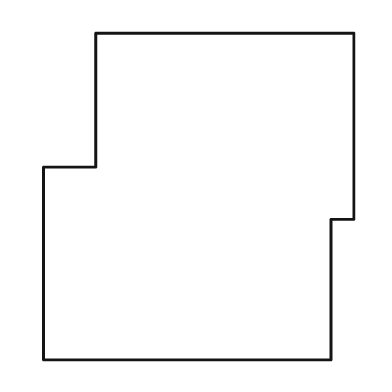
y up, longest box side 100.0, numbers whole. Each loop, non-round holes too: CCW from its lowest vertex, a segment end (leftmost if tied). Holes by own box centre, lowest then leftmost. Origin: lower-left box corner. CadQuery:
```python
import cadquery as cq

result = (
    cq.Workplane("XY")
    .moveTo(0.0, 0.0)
    .lineTo(88.0, 0.0)
    .lineTo(88.0, 43.0)
    .lineTo(95.0, 43.0)
    .lineTo(95.0, 100.0)
    .lineTo(16.0, 100.0)
    .lineTo(16.0, 59.0)
    .lineTo(0.0, 59.0)
    .close()
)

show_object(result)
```